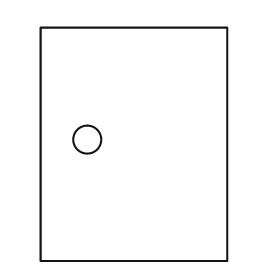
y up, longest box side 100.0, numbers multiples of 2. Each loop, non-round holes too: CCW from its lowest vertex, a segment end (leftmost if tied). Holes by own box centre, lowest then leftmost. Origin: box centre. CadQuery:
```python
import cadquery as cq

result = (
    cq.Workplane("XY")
    .moveTo(-40.0, -50.0)
    .lineTo(40.0, -50.0)
    .lineTo(40.0, 50.0)
    .lineTo(-40.0, 50.0)
    .close()
    .moveTo(-20.0, 2.0)
    .circle(6.0)
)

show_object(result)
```